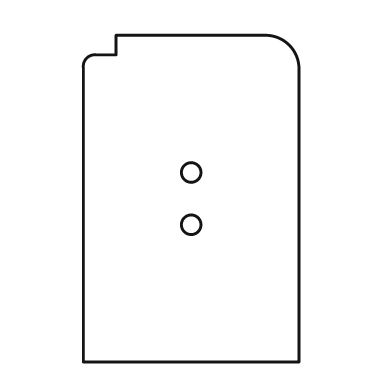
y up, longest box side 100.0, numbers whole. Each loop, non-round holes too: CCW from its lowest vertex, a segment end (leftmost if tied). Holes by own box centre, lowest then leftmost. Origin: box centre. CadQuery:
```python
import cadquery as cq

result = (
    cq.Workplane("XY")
    .moveTo(-33.0, -50.0)
    .lineTo(33.0, -50.0)
    .lineTo(33.0, 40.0)
    .threePointArc((30.0, 47.0), (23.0, 50.0))
    .lineTo(-23.0, 50.0)
    .lineTo(-23.0, 44.0)
    .lineTo(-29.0, 44.0)
    .threePointArc((-32.0, 43.0), (-33.0, 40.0))
    .close()
    .moveTo(0.0, -8.0)
    .circle(3.0)
    .moveTo(0.0, 8.0)
    .circle(3.0)
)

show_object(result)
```